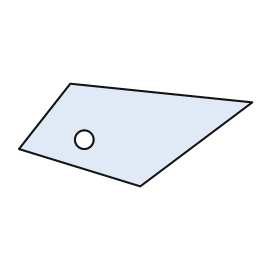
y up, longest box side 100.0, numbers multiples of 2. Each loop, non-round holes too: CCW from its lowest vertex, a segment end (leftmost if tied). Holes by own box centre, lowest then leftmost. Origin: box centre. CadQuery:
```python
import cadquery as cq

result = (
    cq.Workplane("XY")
    .moveTo(2.0, -22.0)
    .lineTo(50.0, 14.0)
    .lineTo(-28.0, 22.0)
    .lineTo(-50.0, -6.0)
    .close()
    .moveTo(-22.0, -2.0)
    .circle(4.0)
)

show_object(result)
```